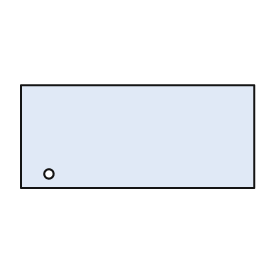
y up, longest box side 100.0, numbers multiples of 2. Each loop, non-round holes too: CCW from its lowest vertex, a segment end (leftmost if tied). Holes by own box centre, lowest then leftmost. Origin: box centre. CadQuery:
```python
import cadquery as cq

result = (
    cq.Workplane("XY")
    .moveTo(-50.0, -22.0)
    .lineTo(50.0, -22.0)
    .lineTo(50.0, 22.0)
    .lineTo(-50.0, 22.0)
    .close()
    .moveTo(-38.0, -16.0)
    .circle(2.0)
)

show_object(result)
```